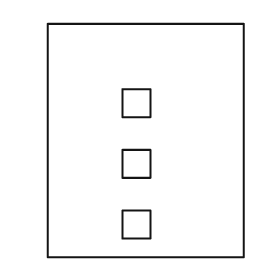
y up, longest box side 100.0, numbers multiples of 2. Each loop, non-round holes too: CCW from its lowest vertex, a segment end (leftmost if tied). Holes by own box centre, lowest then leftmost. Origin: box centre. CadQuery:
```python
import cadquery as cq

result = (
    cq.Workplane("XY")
    .moveTo(-42.0, -50.0)
    .lineTo(42.0, -50.0)
    .lineTo(42.0, 50.0)
    .lineTo(-42.0, 50.0)
    .close()
    .moveTo(-10.0, -42.0)
    .lineTo(2.0, -42.0)
    .lineTo(2.0, -30.0)
    .lineTo(-10.0, -30.0)
    .close()
    .moveTo(-10.0, -16.0)
    .lineTo(2.0, -16.0)
    .lineTo(2.0, -4.0)
    .lineTo(-10.0, -4.0)
    .close()
    .moveTo(-10.0, 10.0)
    .lineTo(2.0, 10.0)
    .lineTo(2.0, 22.0)
    .lineTo(-10.0, 22.0)
    .close()
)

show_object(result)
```